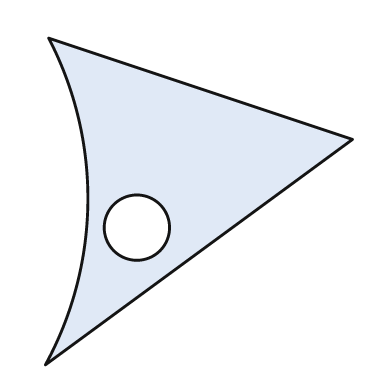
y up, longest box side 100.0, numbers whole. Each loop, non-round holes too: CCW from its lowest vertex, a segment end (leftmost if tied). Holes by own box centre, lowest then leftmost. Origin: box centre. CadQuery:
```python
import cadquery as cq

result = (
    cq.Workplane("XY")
    .moveTo(-47.0, -50.0)
    .lineTo(47.0, 19.0)
    .lineTo(-46.0, 50.0)
    .threePointArc((-34.0, 0.0), (-47.0, -50.0))
    .close()
    .moveTo(-19.0, -8.0)
    .circle(10.0)
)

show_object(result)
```